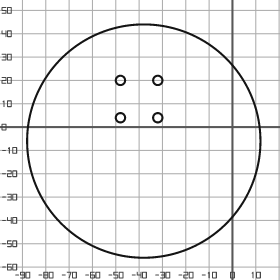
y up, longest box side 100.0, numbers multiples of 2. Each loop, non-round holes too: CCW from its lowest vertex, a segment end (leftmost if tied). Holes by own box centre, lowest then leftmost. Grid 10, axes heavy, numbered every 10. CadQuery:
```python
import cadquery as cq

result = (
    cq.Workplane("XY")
    .moveTo(-38.0, -6.0)
    .circle(50.0)
    .moveTo(-48.0, 4.0)
    .circle(2.0)
    .moveTo(-32.0, 4.0)
    .circle(2.0)
    .moveTo(-48.0, 20.0)
    .circle(2.0)
    .moveTo(-32.0, 20.0)
    .circle(2.0)
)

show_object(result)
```